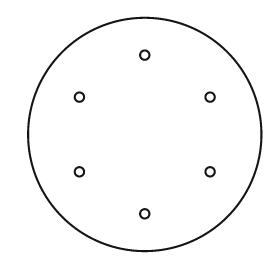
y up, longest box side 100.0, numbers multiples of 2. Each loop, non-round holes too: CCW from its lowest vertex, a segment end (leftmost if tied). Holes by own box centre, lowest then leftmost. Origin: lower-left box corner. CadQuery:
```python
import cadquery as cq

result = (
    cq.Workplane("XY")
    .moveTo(50.0, 50.0)
    .circle(50.0)
    .moveTo(50.0, 16.0)
    .circle(2.0)
    .moveTo(22.0, 34.0)
    .circle(2.0)
    .moveTo(78.0, 34.0)
    .circle(2.0)
    .moveTo(22.0, 66.0)
    .circle(2.0)
    .moveTo(78.0, 66.0)
    .circle(2.0)
    .moveTo(50.0, 84.0)
    .circle(2.0)
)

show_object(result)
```